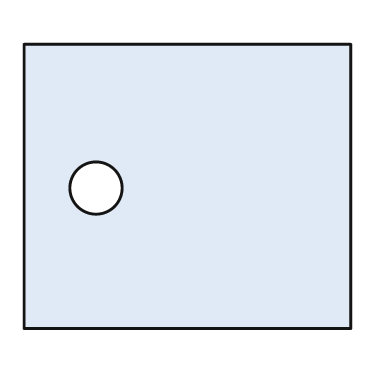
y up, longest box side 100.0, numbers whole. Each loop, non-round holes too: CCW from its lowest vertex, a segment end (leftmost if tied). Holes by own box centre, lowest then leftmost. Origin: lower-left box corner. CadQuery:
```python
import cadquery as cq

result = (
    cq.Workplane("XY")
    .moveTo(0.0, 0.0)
    .lineTo(100.0, 0.0)
    .lineTo(100.0, 87.0)
    .lineTo(0.0, 87.0)
    .close()
    .moveTo(22.0, 43.0)
    .circle(8.0)
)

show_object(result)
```